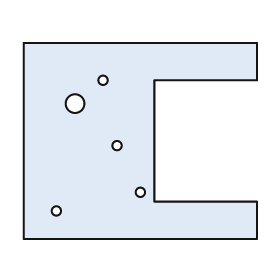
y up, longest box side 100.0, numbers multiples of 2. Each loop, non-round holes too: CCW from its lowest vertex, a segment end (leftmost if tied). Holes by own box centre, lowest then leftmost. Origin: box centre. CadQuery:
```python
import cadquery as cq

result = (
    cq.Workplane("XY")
    .moveTo(-50.0, -42.0)
    .lineTo(50.0, -42.0)
    .lineTo(50.0, -26.0)
    .lineTo(6.0, -26.0)
    .lineTo(6.0, 26.0)
    .lineTo(50.0, 26.0)
    .lineTo(50.0, 42.0)
    .lineTo(-50.0, 42.0)
    .close()
    .moveTo(-36.0, -30.0)
    .circle(2.0)
    .moveTo(0.0, -22.0)
    .circle(2.0)
    .moveTo(-10.0, -2.0)
    .circle(2.0)
    .moveTo(-28.0, 16.0)
    .circle(4.0)
    .moveTo(-16.0, 26.0)
    .circle(2.0)
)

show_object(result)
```